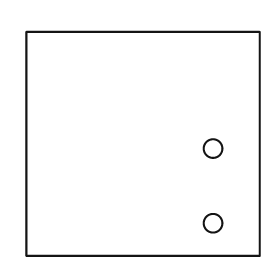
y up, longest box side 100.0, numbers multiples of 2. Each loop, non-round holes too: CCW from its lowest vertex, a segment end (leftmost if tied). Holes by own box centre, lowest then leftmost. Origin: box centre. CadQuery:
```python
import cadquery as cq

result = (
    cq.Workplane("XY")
    .moveTo(-50.0, -48.0)
    .lineTo(50.0, -48.0)
    .lineTo(50.0, 48.0)
    .lineTo(-50.0, 48.0)
    .close()
    .moveTo(30.0, -34.0)
    .circle(4.0)
    .moveTo(30.0, -2.0)
    .circle(4.0)
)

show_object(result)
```